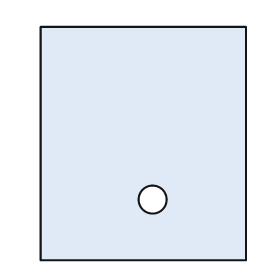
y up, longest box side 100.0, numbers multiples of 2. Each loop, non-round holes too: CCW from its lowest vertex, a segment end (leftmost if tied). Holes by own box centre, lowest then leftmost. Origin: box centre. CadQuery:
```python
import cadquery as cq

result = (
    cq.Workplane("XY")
    .moveTo(-44.0, -50.0)
    .lineTo(44.0, -50.0)
    .lineTo(44.0, 50.0)
    .lineTo(-44.0, 50.0)
    .close()
    .moveTo(4.0, -24.0)
    .circle(6.0)
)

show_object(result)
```